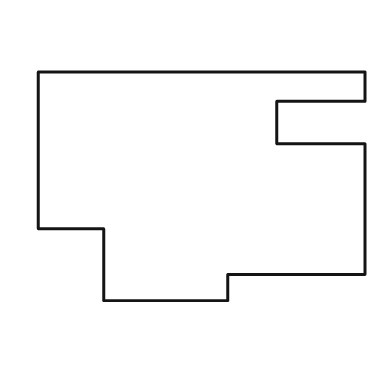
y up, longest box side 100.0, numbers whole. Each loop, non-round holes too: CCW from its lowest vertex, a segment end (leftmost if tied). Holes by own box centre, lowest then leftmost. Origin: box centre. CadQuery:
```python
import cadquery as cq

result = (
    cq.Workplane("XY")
    .moveTo(-30.0, -35.0)
    .lineTo(8.0, -35.0)
    .lineTo(8.0, -27.0)
    .lineTo(50.0, -27.0)
    .lineTo(50.0, 13.0)
    .lineTo(23.0, 13.0)
    .lineTo(23.0, 26.0)
    .lineTo(50.0, 26.0)
    .lineTo(50.0, 35.0)
    .lineTo(-50.0, 35.0)
    .lineTo(-50.0, -13.0)
    .lineTo(-30.0, -13.0)
    .close()
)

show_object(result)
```